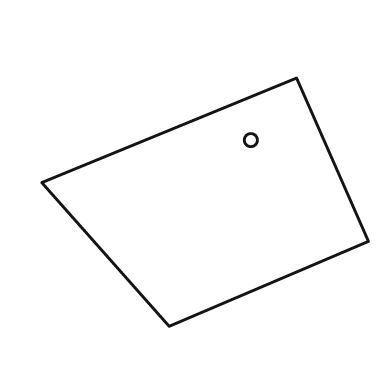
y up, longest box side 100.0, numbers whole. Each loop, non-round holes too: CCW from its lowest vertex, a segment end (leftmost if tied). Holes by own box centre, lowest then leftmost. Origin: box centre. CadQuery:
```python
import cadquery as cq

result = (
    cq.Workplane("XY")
    .moveTo(-11.0, -38.0)
    .lineTo(50.0, -12.0)
    .lineTo(28.0, 38.0)
    .lineTo(-50.0, 6.0)
    .close()
    .moveTo(14.0, 19.0)
    .circle(2.0)
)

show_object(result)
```